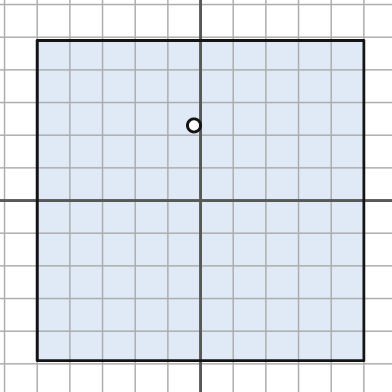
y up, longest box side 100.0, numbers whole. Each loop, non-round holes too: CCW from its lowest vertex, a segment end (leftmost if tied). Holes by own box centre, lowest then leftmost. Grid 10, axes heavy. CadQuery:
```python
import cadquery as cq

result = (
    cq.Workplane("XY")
    .moveTo(-50.0, -49.0)
    .lineTo(50.0, -49.0)
    .lineTo(50.0, 49.0)
    .lineTo(-50.0, 49.0)
    .close()
    .moveTo(-2.0, 23.0)
    .circle(2.0)
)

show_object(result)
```